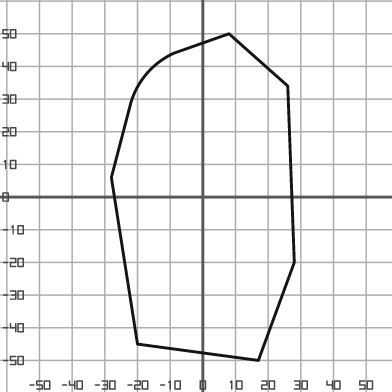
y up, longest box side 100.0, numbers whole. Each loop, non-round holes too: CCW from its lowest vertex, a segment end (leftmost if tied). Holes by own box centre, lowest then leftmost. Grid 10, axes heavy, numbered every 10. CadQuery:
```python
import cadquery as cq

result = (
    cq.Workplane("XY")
    .moveTo(17.0, -50.0)
    .lineTo(28.0, -20.0)
    .lineTo(26.0, 34.0)
    .lineTo(8.0, 50.0)
    .lineTo(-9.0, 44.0)
    .threePointArc((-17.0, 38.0), (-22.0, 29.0))
    .lineTo(-28.0, 6.0)
    .lineTo(-20.0, -45.0)
    .close()
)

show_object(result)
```